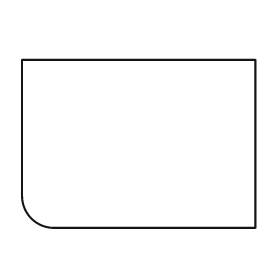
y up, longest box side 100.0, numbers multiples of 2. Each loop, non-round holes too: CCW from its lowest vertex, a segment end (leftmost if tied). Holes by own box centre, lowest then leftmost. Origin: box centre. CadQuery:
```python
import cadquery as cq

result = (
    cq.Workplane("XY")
    .moveTo(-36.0, -36.0)
    .lineTo(50.0, -36.0)
    .lineTo(50.0, 36.0)
    .lineTo(-50.0, 36.0)
    .lineTo(-50.0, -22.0)
    .threePointArc((-46.0, -32.0), (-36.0, -36.0))
    .close()
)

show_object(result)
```